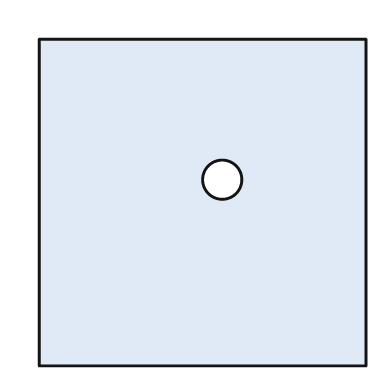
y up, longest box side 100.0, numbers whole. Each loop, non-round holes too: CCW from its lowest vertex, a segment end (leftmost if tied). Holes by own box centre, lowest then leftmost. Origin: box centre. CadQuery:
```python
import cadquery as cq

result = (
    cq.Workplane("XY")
    .moveTo(-50.0, -50.0)
    .lineTo(50.0, -50.0)
    .lineTo(50.0, 50.0)
    .lineTo(-50.0, 50.0)
    .close()
    .moveTo(6.0, 7.0)
    .circle(6.0)
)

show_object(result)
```